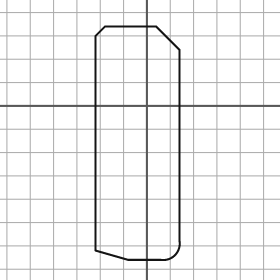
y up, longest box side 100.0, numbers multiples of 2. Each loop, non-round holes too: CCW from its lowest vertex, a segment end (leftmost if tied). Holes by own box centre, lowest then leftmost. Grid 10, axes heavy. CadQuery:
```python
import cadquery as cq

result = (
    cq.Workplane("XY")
    .moveTo(-8.0, -66.0)
    .lineTo(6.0, -66.0)
    .threePointArc((12.0, -64.0), (14.0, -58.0))
    .lineTo(14.0, 24.0)
    .lineTo(4.0, 34.0)
    .lineTo(-18.0, 34.0)
    .lineTo(-22.0, 30.0)
    .lineTo(-22.0, -62.0)
    .close()
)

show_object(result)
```